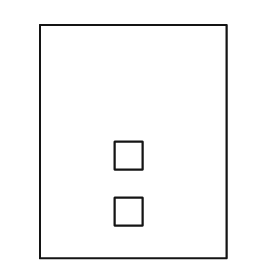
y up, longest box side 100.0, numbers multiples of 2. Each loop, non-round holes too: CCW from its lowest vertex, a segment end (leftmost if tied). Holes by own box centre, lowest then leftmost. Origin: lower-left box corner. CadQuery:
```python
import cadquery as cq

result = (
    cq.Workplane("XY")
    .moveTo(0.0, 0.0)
    .lineTo(80.0, 0.0)
    .lineTo(80.0, 100.0)
    .lineTo(0.0, 100.0)
    .close()
    .moveTo(32.0, 14.0)
    .lineTo(44.0, 14.0)
    .lineTo(44.0, 26.0)
    .lineTo(32.0, 26.0)
    .close()
    .moveTo(32.0, 38.0)
    .lineTo(44.0, 38.0)
    .lineTo(44.0, 50.0)
    .lineTo(32.0, 50.0)
    .close()
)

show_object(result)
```